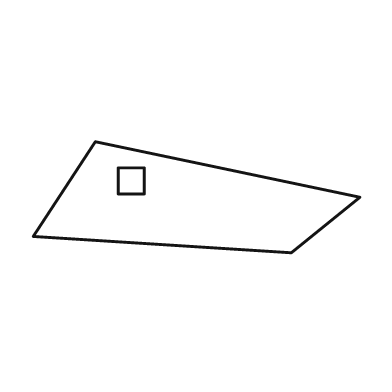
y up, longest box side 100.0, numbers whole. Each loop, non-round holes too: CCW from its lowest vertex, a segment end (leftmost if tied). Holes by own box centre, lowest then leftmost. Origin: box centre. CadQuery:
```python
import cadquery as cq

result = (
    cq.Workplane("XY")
    .moveTo(29.0, -17.0)
    .lineTo(50.0, 0.0)
    .lineTo(-31.0, 17.0)
    .lineTo(-50.0, -12.0)
    .close()
    .moveTo(-24.0, 1.0)
    .lineTo(-16.0, 1.0)
    .lineTo(-16.0, 9.0)
    .lineTo(-24.0, 9.0)
    .close()
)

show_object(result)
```